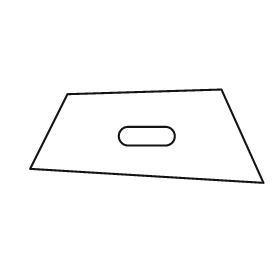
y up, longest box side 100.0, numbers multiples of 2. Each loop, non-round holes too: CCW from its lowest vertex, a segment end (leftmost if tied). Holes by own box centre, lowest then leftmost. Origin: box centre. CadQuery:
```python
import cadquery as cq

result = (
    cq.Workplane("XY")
    .moveTo(50.0, -20.0)
    .lineTo(32.0, 20.0)
    .lineTo(-34.0, 18.0)
    .lineTo(-50.0, -14.0)
    .close()
    .moveTo(-8.0, -4.0)
    .lineTo(8.0, -4.0)
    .threePointArc((12.0, 0.0), (8.0, 4.0))
    .lineTo(-8.0, 4.0)
    .threePointArc((-12.0, 0.0), (-8.0, -4.0))
    .close()
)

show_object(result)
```